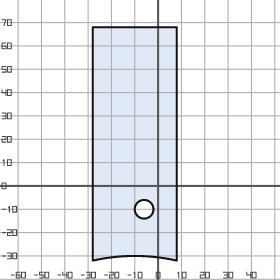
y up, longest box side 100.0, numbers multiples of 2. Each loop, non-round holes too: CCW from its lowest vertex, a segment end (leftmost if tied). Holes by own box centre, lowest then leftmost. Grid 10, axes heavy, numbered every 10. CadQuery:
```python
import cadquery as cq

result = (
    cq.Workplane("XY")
    .moveTo(-28.0, -32.0)
    .threePointArc((-10.0, -30.0), (8.0, -32.0))
    .lineTo(8.0, 68.0)
    .lineTo(-28.0, 68.0)
    .close()
    .moveTo(-6.0, -10.0)
    .circle(4.0)
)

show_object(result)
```